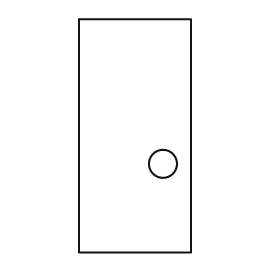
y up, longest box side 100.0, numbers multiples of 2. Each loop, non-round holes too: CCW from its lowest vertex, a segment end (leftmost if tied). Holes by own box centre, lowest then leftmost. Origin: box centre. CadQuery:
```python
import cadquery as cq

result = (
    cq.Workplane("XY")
    .moveTo(-24.0, -50.0)
    .lineTo(24.0, -50.0)
    .lineTo(24.0, 50.0)
    .lineTo(-24.0, 50.0)
    .close()
    .moveTo(12.0, -12.0)
    .circle(6.0)
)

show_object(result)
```